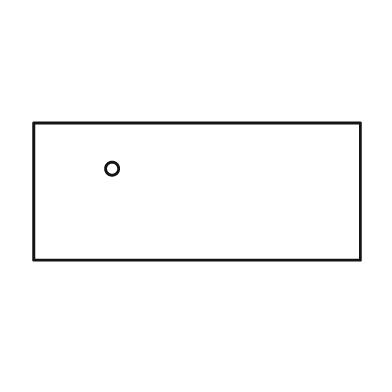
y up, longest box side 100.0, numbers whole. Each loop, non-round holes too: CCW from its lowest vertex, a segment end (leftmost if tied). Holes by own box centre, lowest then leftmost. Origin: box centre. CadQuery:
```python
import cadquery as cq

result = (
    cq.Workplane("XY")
    .moveTo(-50.0, -21.0)
    .lineTo(50.0, -21.0)
    .lineTo(50.0, 21.0)
    .lineTo(-50.0, 21.0)
    .close()
    .moveTo(-26.0, 7.0)
    .circle(2.0)
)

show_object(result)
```